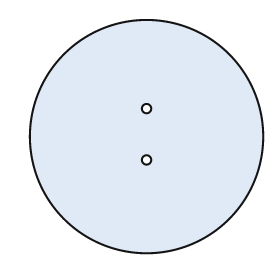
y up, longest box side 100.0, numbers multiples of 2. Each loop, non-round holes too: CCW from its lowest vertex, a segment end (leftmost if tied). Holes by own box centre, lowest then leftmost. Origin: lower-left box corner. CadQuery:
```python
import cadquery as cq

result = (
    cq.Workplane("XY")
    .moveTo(50.0, 50.0)
    .circle(50.0)
    .moveTo(50.0, 40.0)
    .circle(2.0)
    .moveTo(50.0, 62.0)
    .circle(2.0)
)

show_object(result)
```